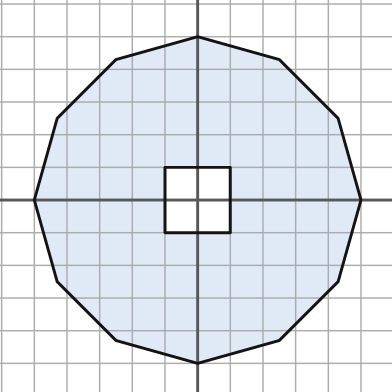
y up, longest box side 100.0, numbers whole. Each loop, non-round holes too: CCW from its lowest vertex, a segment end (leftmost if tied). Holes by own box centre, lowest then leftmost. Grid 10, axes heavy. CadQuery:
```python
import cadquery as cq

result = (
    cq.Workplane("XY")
    .moveTo(0.0, -50.0)
    .lineTo(25.0, -43.0)
    .lineTo(43.0, -25.0)
    .lineTo(50.0, 0.0)
    .lineTo(43.0, 25.0)
    .lineTo(25.0, 43.0)
    .lineTo(0.0, 50.0)
    .lineTo(-25.0, 43.0)
    .lineTo(-43.0, 25.0)
    .lineTo(-50.0, 0.0)
    .lineTo(-43.0, -25.0)
    .lineTo(-25.0, -43.0)
    .close()
    .moveTo(-10.0, -10.0)
    .lineTo(10.0, -10.0)
    .lineTo(10.0, 10.0)
    .lineTo(-10.0, 10.0)
    .close()
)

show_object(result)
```